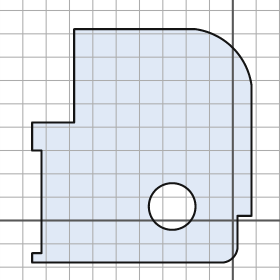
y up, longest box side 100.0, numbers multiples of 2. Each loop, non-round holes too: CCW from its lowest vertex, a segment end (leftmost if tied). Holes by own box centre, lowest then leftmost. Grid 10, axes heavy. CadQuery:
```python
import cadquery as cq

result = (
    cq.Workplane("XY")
    .moveTo(-86.0, -18.0)
    .lineTo(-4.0, -18.0)
    .threePointArc((0.0, -16.0), (2.0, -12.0))
    .lineTo(2.0, 2.0)
    .lineTo(8.0, 2.0)
    .lineTo(8.0, 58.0)
    .threePointArc((0.0, 74.0), (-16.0, 82.0))
    .lineTo(-68.0, 82.0)
    .lineTo(-68.0, 42.0)
    .lineTo(-86.0, 42.0)
    .lineTo(-86.0, 30.0)
    .lineTo(-82.0, 30.0)
    .lineTo(-82.0, -14.0)
    .lineTo(-86.0, -14.0)
    .close()
    .moveTo(-26.0, 6.0)
    .circle(10.0)
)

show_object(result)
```